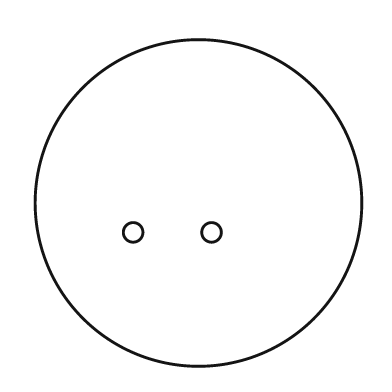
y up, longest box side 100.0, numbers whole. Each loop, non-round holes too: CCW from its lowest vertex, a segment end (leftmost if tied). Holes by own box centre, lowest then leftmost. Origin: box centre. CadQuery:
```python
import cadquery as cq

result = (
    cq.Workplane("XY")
    .moveTo(0.0, 0.0)
    .circle(50.0)
    .moveTo(-20.0, -9.0)
    .circle(3.0)
    .moveTo(4.0, -9.0)
    .circle(3.0)
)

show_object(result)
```